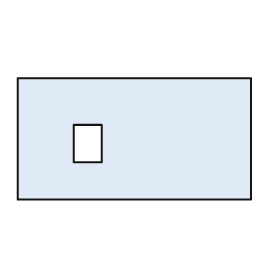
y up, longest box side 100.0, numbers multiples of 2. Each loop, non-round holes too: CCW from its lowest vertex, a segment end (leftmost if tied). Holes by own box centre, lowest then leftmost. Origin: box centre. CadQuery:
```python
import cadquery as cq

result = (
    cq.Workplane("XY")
    .moveTo(-50.0, -26.0)
    .lineTo(50.0, -26.0)
    .lineTo(50.0, 26.0)
    .lineTo(-50.0, 26.0)
    .close()
    .moveTo(-26.0, -10.0)
    .lineTo(-14.0, -10.0)
    .lineTo(-14.0, 6.0)
    .lineTo(-26.0, 6.0)
    .close()
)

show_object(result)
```